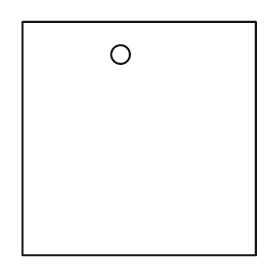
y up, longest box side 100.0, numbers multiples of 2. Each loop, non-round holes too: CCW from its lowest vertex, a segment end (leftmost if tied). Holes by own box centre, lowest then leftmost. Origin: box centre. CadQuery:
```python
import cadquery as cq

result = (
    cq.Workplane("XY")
    .moveTo(-50.0, -50.0)
    .lineTo(50.0, -50.0)
    .lineTo(50.0, 50.0)
    .lineTo(-50.0, 50.0)
    .close()
    .moveTo(-8.0, 36.0)
    .circle(4.0)
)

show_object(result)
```